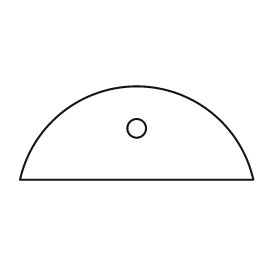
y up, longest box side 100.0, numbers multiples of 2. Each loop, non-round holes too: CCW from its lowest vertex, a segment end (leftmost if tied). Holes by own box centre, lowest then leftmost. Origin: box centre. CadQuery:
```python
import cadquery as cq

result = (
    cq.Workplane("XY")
    .moveTo(-50.0, -20.0)
    .lineTo(50.0, -20.0)
    .threePointArc((0.0, 20.0), (-50.0, -20.0))
    .close()
    .moveTo(0.0, 2.0)
    .circle(4.0)
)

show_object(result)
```